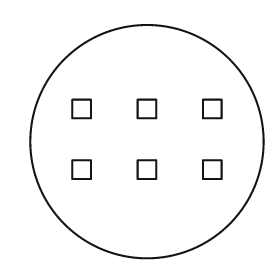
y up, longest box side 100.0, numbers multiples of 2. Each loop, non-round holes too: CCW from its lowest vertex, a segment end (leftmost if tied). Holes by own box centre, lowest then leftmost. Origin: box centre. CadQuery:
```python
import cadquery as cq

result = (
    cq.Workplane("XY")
    .moveTo(0.0, 0.0)
    .circle(50.0)
    .moveTo(-32.0, -16.0)
    .lineTo(-24.0, -16.0)
    .lineTo(-24.0, -8.0)
    .lineTo(-32.0, -8.0)
    .close()
    .moveTo(-4.0, -16.0)
    .lineTo(4.0, -16.0)
    .lineTo(4.0, -8.0)
    .lineTo(-4.0, -8.0)
    .close()
    .moveTo(24.0, -16.0)
    .lineTo(32.0, -16.0)
    .lineTo(32.0, -8.0)
    .lineTo(24.0, -8.0)
    .close()
    .moveTo(-32.0, 10.0)
    .lineTo(-24.0, 10.0)
    .lineTo(-24.0, 18.0)
    .lineTo(-32.0, 18.0)
    .close()
    .moveTo(-4.0, 10.0)
    .lineTo(4.0, 10.0)
    .lineTo(4.0, 18.0)
    .lineTo(-4.0, 18.0)
    .close()
    .moveTo(24.0, 10.0)
    .lineTo(32.0, 10.0)
    .lineTo(32.0, 18.0)
    .lineTo(24.0, 18.0)
    .close()
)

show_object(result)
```